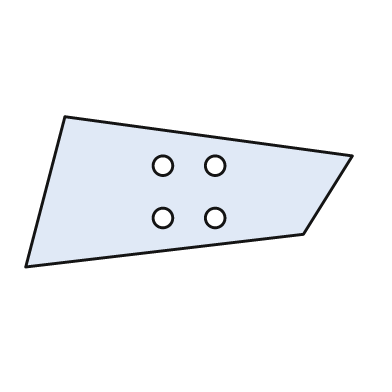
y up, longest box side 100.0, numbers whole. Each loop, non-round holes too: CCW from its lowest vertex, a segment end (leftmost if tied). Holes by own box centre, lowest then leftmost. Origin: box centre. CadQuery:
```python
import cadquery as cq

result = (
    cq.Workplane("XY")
    .moveTo(-50.0, -23.0)
    .lineTo(35.0, -13.0)
    .lineTo(50.0, 11.0)
    .lineTo(-38.0, 23.0)
    .close()
    .moveTo(-8.0, -8.0)
    .circle(3.0)
    .moveTo(8.0, -8.0)
    .circle(3.0)
    .moveTo(-8.0, 8.0)
    .circle(3.0)
    .moveTo(8.0, 8.0)
    .circle(3.0)
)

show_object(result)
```